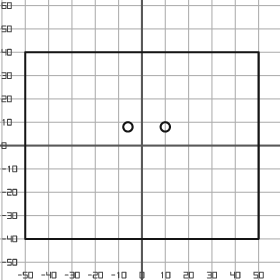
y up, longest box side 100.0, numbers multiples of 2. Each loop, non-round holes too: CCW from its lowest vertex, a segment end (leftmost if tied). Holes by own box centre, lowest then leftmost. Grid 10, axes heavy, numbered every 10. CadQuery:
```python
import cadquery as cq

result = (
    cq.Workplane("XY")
    .moveTo(-50.0, -40.0)
    .lineTo(50.0, -40.0)
    .lineTo(50.0, 40.0)
    .lineTo(-50.0, 40.0)
    .close()
    .moveTo(-6.0, 8.0)
    .circle(2.0)
    .moveTo(10.0, 8.0)
    .circle(2.0)
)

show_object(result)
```